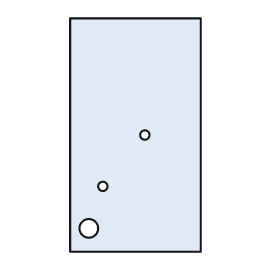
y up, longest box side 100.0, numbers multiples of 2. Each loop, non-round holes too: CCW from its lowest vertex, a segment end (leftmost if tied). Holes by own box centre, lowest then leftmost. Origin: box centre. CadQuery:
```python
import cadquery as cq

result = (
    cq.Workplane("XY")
    .moveTo(-28.0, -50.0)
    .lineTo(28.0, -50.0)
    .lineTo(28.0, 50.0)
    .lineTo(-28.0, 50.0)
    .close()
    .moveTo(-20.0, -40.0)
    .circle(4.0)
    .moveTo(-14.0, -22.0)
    .circle(2.0)
    .moveTo(4.0, 0.0)
    .circle(2.0)
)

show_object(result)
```